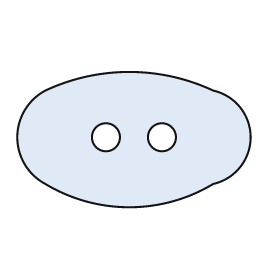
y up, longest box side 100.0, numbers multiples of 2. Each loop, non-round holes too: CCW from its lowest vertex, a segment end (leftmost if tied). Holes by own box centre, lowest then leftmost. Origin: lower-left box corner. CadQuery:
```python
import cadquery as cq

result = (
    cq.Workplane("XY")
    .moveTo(12.0, 10.0)
    .threePointArc((48.0, 0.0), (84.0, 10.0))
    .threePointArc((100.0, 30.0), (84.0, 50.0))
    .threePointArc((48.0, 58.0), (12.0, 50.0))
    .threePointArc((0.0, 30.0), (12.0, 10.0))
    .close()
    .moveTo(38.0, 30.0)
    .circle(6.0)
    .moveTo(62.0, 30.0)
    .circle(6.0)
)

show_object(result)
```